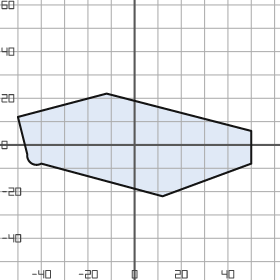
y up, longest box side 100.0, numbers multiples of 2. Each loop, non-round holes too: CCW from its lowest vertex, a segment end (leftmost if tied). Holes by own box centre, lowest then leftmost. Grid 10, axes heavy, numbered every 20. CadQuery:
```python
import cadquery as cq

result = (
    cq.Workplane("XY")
    .moveTo(12.0, -22.0)
    .lineTo(50.0, -8.0)
    .lineTo(50.0, 6.0)
    .lineTo(-12.0, 22.0)
    .lineTo(-50.0, 12.0)
    .lineTo(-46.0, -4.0)
    .threePointArc((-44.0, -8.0), (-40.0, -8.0))
    .close()
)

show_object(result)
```